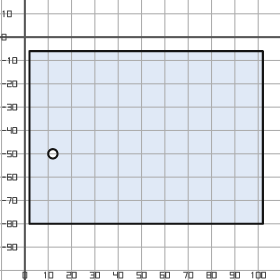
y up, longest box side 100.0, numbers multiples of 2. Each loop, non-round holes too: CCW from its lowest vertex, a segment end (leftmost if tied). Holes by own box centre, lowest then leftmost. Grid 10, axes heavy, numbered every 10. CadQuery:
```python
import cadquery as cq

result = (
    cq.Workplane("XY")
    .moveTo(2.0, -80.0)
    .lineTo(102.0, -80.0)
    .lineTo(102.0, -6.0)
    .lineTo(2.0, -6.0)
    .close()
    .moveTo(12.0, -50.0)
    .circle(2.0)
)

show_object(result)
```